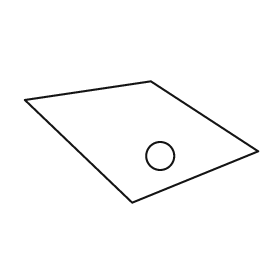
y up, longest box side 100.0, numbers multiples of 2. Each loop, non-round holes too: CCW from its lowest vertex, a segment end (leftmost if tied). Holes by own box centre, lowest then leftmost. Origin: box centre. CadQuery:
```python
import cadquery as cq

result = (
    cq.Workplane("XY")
    .moveTo(-4.0, -26.0)
    .lineTo(50.0, -4.0)
    .lineTo(4.0, 26.0)
    .lineTo(-50.0, 18.0)
    .close()
    .moveTo(8.0, -6.0)
    .circle(6.0)
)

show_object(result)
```